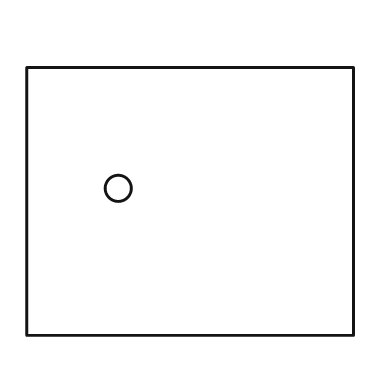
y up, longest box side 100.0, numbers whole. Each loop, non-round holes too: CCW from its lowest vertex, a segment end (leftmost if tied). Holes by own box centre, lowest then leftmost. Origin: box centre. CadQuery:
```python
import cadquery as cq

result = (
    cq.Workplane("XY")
    .moveTo(-50.0, -41.0)
    .lineTo(50.0, -41.0)
    .lineTo(50.0, 41.0)
    .lineTo(-50.0, 41.0)
    .close()
    .moveTo(-22.0, 4.0)
    .circle(4.0)
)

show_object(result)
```